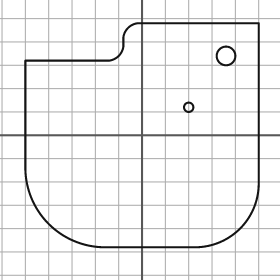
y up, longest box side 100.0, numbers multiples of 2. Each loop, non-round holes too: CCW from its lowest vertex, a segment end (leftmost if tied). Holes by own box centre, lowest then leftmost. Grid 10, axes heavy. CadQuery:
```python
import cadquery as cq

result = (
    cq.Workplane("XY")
    .moveTo(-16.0, -48.0)
    .lineTo(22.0, -48.0)
    .threePointArc((42.0, -40.0), (50.0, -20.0))
    .lineTo(50.0, 48.0)
    .lineTo(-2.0, 48.0)
    .threePointArc((-6.0, 46.0), (-8.0, 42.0))
    .lineTo(-8.0, 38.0)
    .threePointArc((-10.0, 34.0), (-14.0, 32.0))
    .lineTo(-50.0, 32.0)
    .lineTo(-50.0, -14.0)
    .threePointArc((-40.0, -38.0), (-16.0, -48.0))
    .close()
    .moveTo(20.0, 12.0)
    .circle(2.0)
    .moveTo(36.0, 34.0)
    .circle(4.0)
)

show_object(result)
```